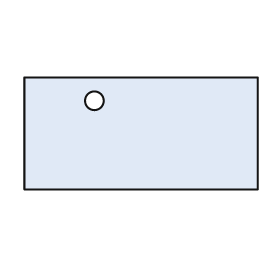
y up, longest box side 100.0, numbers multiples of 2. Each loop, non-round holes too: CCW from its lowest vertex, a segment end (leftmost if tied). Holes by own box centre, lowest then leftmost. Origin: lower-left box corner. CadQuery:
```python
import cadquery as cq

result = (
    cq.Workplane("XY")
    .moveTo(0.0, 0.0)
    .lineTo(100.0, 0.0)
    .lineTo(100.0, 48.0)
    .lineTo(0.0, 48.0)
    .close()
    .moveTo(30.0, 38.0)
    .circle(4.0)
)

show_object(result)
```